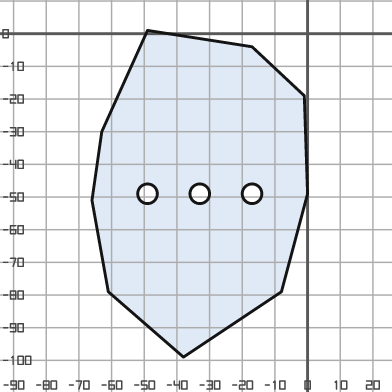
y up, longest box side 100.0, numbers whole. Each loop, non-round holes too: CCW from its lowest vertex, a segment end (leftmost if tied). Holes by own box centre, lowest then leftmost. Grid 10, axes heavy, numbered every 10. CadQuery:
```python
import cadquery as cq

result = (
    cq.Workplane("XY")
    .moveTo(-38.0, -99.0)
    .lineTo(-8.0, -79.0)
    .lineTo(0.0, -49.0)
    .lineTo(-1.0, -19.0)
    .lineTo(-17.0, -4.0)
    .lineTo(-49.0, 1.0)
    .lineTo(-63.0, -30.0)
    .lineTo(-66.0, -51.0)
    .lineTo(-61.0, -79.0)
    .close()
    .moveTo(-49.0, -49.0)
    .circle(3.0)
    .moveTo(-33.0, -49.0)
    .circle(3.0)
    .moveTo(-17.0, -49.0)
    .circle(3.0)
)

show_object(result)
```